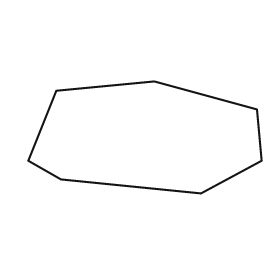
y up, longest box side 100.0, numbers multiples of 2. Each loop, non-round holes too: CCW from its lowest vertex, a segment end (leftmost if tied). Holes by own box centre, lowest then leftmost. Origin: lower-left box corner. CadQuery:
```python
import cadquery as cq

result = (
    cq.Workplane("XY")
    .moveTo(74.0, 0.0)
    .lineTo(100.0, 14.0)
    .lineTo(98.0, 36.0)
    .lineTo(54.0, 48.0)
    .lineTo(12.0, 44.0)
    .lineTo(0.0, 14.0)
    .lineTo(14.0, 6.0)
    .close()
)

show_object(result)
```